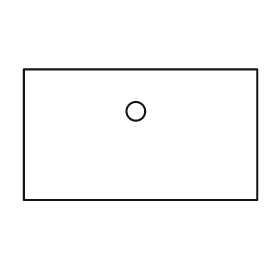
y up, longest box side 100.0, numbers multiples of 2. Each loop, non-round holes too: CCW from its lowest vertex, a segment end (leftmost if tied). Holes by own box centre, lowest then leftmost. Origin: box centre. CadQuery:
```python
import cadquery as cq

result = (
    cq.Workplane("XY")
    .moveTo(-50.0, -28.0)
    .lineTo(50.0, -28.0)
    .lineTo(50.0, 28.0)
    .lineTo(-50.0, 28.0)
    .close()
    .moveTo(-2.0, 10.0)
    .circle(4.0)
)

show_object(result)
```